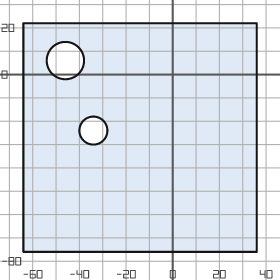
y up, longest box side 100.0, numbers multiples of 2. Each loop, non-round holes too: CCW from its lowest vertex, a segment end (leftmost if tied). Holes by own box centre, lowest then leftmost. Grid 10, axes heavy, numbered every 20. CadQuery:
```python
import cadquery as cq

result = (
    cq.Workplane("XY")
    .moveTo(-64.0, -76.0)
    .lineTo(36.0, -76.0)
    .lineTo(36.0, 22.0)
    .lineTo(-64.0, 22.0)
    .close()
    .moveTo(-34.0, -24.0)
    .circle(6.0)
    .moveTo(-46.0, 6.0)
    .circle(8.0)
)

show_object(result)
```